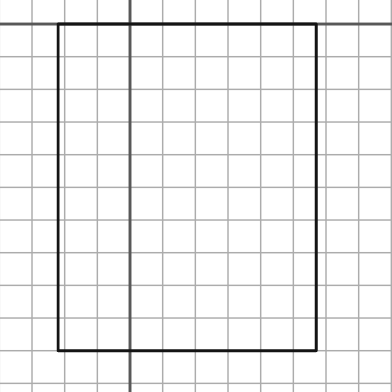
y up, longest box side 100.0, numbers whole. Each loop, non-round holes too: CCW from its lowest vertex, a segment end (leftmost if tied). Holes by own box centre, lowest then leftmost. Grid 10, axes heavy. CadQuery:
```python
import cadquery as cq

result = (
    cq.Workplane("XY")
    .moveTo(-22.0, -100.0)
    .lineTo(57.0, -100.0)
    .lineTo(57.0, 0.0)
    .lineTo(-22.0, 0.0)
    .close()
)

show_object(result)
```